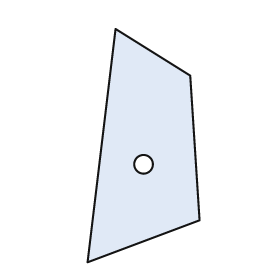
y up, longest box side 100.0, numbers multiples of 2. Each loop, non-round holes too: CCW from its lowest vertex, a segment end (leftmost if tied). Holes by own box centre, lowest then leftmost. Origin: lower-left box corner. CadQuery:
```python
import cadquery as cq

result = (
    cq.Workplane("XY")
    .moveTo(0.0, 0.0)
    .lineTo(48.0, 18.0)
    .lineTo(44.0, 80.0)
    .lineTo(12.0, 100.0)
    .close()
    .moveTo(24.0, 42.0)
    .circle(4.0)
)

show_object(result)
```